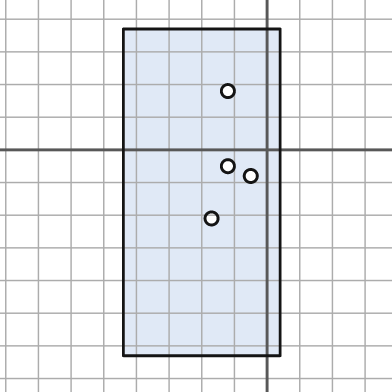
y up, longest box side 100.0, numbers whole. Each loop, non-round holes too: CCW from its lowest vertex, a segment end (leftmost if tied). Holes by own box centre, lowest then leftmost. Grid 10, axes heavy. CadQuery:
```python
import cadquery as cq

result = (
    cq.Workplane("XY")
    .moveTo(-44.0, -63.0)
    .lineTo(4.0, -63.0)
    .lineTo(4.0, 37.0)
    .lineTo(-44.0, 37.0)
    .close()
    .moveTo(-17.0, -21.0)
    .circle(2.0)
    .moveTo(-5.0, -8.0)
    .circle(2.0)
    .moveTo(-12.0, -5.0)
    .circle(2.0)
    .moveTo(-12.0, 18.0)
    .circle(2.0)
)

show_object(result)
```